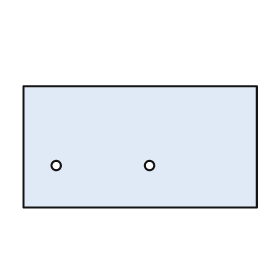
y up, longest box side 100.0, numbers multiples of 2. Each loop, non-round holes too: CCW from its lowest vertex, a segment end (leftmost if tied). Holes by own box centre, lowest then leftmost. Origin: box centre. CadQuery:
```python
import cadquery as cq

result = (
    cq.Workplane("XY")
    .moveTo(-50.0, -26.0)
    .lineTo(50.0, -26.0)
    .lineTo(50.0, 26.0)
    .lineTo(-50.0, 26.0)
    .close()
    .moveTo(-36.0, -8.0)
    .circle(2.0)
    .moveTo(4.0, -8.0)
    .circle(2.0)
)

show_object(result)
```